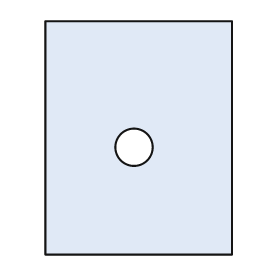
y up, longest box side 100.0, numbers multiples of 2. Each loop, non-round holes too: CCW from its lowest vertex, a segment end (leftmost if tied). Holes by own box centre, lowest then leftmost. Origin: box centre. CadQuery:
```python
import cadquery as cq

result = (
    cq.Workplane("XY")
    .moveTo(-40.0, -50.0)
    .lineTo(40.0, -50.0)
    .lineTo(40.0, 50.0)
    .lineTo(-40.0, 50.0)
    .close()
    .moveTo(-2.0, -4.0)
    .circle(8.0)
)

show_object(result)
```